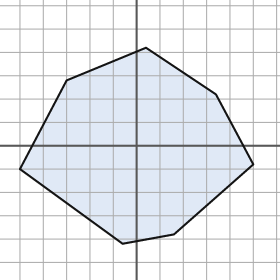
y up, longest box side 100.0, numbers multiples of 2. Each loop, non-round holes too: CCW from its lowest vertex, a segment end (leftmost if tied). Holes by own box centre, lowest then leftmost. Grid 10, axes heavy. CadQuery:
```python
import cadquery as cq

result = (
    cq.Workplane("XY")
    .moveTo(-6.0, -42.0)
    .lineTo(16.0, -38.0)
    .lineTo(50.0, -8.0)
    .lineTo(34.0, 22.0)
    .lineTo(4.0, 42.0)
    .lineTo(-30.0, 28.0)
    .lineTo(-50.0, -10.0)
    .close()
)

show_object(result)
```